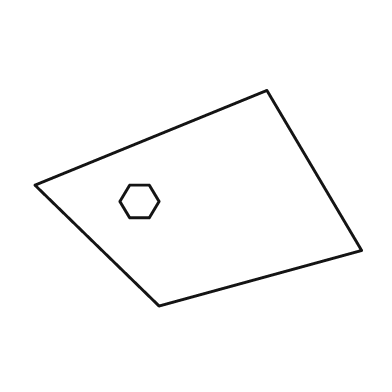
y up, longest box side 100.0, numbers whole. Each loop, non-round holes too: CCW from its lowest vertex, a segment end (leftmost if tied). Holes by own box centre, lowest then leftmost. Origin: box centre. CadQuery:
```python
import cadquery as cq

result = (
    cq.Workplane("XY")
    .moveTo(-12.0, -33.0)
    .lineTo(50.0, -16.0)
    .lineTo(21.0, 33.0)
    .lineTo(-50.0, 4.0)
    .close()
    .moveTo(-21.0, -6.0)
    .lineTo(-15.0, -6.0)
    .lineTo(-12.0, -1.0)
    .lineTo(-15.0, 4.0)
    .lineTo(-21.0, 4.0)
    .lineTo(-24.0, -1.0)
    .close()
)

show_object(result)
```